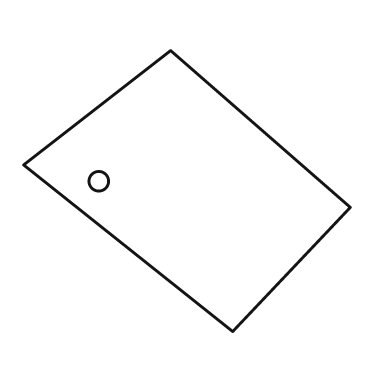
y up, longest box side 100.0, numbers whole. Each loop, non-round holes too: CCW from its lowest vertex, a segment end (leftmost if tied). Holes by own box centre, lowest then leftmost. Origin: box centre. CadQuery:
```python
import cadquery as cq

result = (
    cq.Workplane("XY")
    .moveTo(14.0, -43.0)
    .lineTo(50.0, -5.0)
    .lineTo(-5.0, 43.0)
    .lineTo(-50.0, 8.0)
    .close()
    .moveTo(-27.0, 3.0)
    .circle(3.0)
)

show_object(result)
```